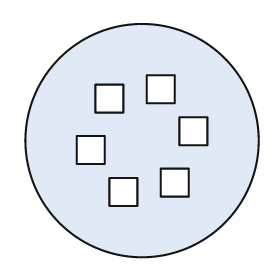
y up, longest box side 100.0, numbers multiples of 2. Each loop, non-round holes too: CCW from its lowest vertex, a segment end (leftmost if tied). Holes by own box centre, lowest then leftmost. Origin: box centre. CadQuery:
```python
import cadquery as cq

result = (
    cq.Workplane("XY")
    .moveTo(0.0, 0.0)
    .circle(50.0)
    .moveTo(-14.0, -28.0)
    .lineTo(-2.0, -28.0)
    .lineTo(-2.0, -16.0)
    .lineTo(-14.0, -16.0)
    .close()
    .moveTo(8.0, -24.0)
    .lineTo(20.0, -24.0)
    .lineTo(20.0, -12.0)
    .lineTo(8.0, -12.0)
    .close()
    .moveTo(-28.0, -10.0)
    .lineTo(-16.0, -10.0)
    .lineTo(-16.0, 2.0)
    .lineTo(-28.0, 2.0)
    .close()
    .moveTo(16.0, -2.0)
    .lineTo(28.0, -2.0)
    .lineTo(28.0, 10.0)
    .lineTo(16.0, 10.0)
    .close()
    .moveTo(-20.0, 12.0)
    .lineTo(-8.0, 12.0)
    .lineTo(-8.0, 24.0)
    .lineTo(-20.0, 24.0)
    .close()
    .moveTo(2.0, 16.0)
    .lineTo(14.0, 16.0)
    .lineTo(14.0, 28.0)
    .lineTo(2.0, 28.0)
    .close()
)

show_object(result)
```